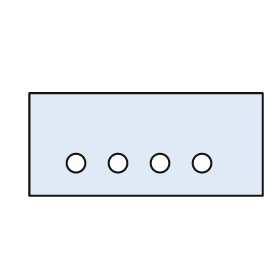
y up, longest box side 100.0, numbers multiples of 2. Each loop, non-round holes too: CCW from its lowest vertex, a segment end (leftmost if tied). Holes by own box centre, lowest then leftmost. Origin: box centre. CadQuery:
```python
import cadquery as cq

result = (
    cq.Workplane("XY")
    .moveTo(-50.0, -22.0)
    .lineTo(50.0, -22.0)
    .lineTo(50.0, 22.0)
    .lineTo(-50.0, 22.0)
    .close()
    .moveTo(-30.0, -8.0)
    .circle(4.0)
    .moveTo(-12.0, -8.0)
    .circle(4.0)
    .moveTo(6.0, -8.0)
    .circle(4.0)
    .moveTo(24.0, -8.0)
    .circle(4.0)
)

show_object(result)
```